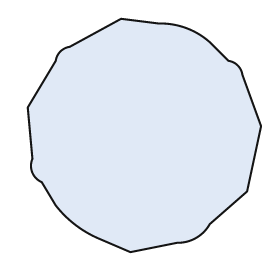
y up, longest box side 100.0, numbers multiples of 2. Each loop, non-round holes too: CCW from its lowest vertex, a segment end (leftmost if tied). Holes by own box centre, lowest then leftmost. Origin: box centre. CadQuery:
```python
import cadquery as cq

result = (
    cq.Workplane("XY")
    .moveTo(-6.0, -50.0)
    .lineTo(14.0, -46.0)
    .threePointArc((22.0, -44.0), (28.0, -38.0))
    .lineTo(44.0, -24.0)
    .lineTo(50.0, 4.0)
    .lineTo(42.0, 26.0)
    .threePointArc((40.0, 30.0), (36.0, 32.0))
    .lineTo(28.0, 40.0)
    .threePointArc((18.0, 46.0), (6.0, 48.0))
    .lineTo(-10.0, 50.0)
    .lineTo(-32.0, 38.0)
    .threePointArc((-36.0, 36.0), (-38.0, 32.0))
    .lineTo(-50.0, 12.0)
    .lineTo(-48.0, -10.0)
    .threePointArc((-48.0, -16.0), (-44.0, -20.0))
    .lineTo(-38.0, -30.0)
    .threePointArc((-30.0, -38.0), (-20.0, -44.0))
    .close()
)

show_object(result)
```